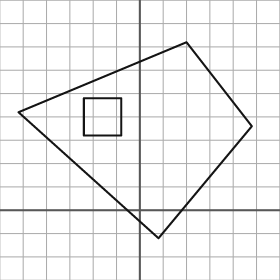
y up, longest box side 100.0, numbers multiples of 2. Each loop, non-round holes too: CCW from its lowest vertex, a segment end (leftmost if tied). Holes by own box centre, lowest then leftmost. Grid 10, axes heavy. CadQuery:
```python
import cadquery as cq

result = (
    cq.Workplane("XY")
    .moveTo(8.0, -12.0)
    .lineTo(48.0, 36.0)
    .lineTo(20.0, 72.0)
    .lineTo(-52.0, 42.0)
    .close()
    .moveTo(-24.0, 32.0)
    .lineTo(-8.0, 32.0)
    .lineTo(-8.0, 48.0)
    .lineTo(-24.0, 48.0)
    .close()
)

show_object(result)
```